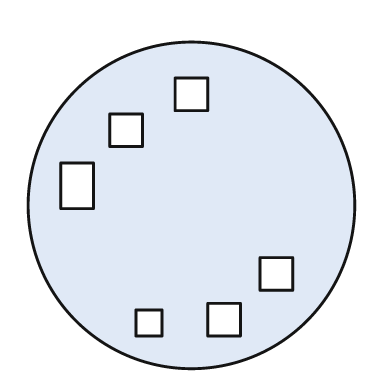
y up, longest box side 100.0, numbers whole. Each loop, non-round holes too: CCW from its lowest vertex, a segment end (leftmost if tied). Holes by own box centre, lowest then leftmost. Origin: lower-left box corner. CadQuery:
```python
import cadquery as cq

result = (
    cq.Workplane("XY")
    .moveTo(50.0, 50.0)
    .circle(50.0)
    .moveTo(33.0, 10.0)
    .lineTo(41.0, 10.0)
    .lineTo(41.0, 18.0)
    .lineTo(33.0, 18.0)
    .close()
    .moveTo(55.0, 10.0)
    .lineTo(65.0, 10.0)
    .lineTo(65.0, 20.0)
    .lineTo(55.0, 20.0)
    .close()
    .moveTo(71.0, 24.0)
    .lineTo(81.0, 24.0)
    .lineTo(81.0, 34.0)
    .lineTo(71.0, 34.0)
    .close()
    .moveTo(10.0, 49.0)
    .lineTo(20.0, 49.0)
    .lineTo(20.0, 63.0)
    .lineTo(10.0, 63.0)
    .close()
    .moveTo(25.0, 68.0)
    .lineTo(35.0, 68.0)
    .lineTo(35.0, 78.0)
    .lineTo(25.0, 78.0)
    .close()
    .moveTo(45.0, 79.0)
    .lineTo(55.0, 79.0)
    .lineTo(55.0, 89.0)
    .lineTo(45.0, 89.0)
    .close()
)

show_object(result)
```